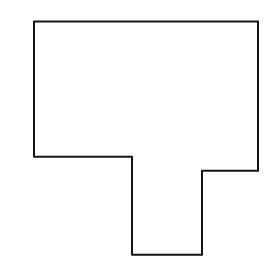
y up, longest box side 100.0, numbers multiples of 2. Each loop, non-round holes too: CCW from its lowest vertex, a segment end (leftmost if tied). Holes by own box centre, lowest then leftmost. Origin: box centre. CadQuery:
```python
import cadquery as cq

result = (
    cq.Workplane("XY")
    .moveTo(-6.0, -50.0)
    .lineTo(24.0, -50.0)
    .lineTo(24.0, -14.0)
    .lineTo(48.0, -14.0)
    .lineTo(48.0, 50.0)
    .lineTo(-48.0, 50.0)
    .lineTo(-48.0, -8.0)
    .lineTo(-6.0, -8.0)
    .close()
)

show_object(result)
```